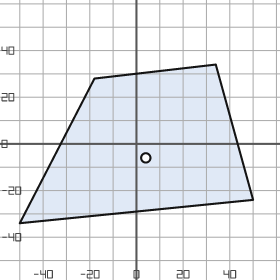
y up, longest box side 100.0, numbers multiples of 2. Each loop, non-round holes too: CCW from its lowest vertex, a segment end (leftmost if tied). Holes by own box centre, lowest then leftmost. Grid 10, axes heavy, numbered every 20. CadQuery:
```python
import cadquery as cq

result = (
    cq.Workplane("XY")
    .moveTo(-50.0, -34.0)
    .lineTo(50.0, -24.0)
    .lineTo(34.0, 34.0)
    .lineTo(-18.0, 28.0)
    .close()
    .moveTo(4.0, -6.0)
    .circle(2.0)
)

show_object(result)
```